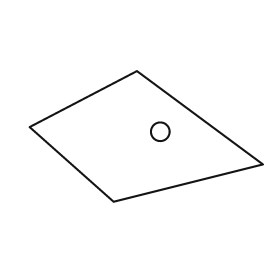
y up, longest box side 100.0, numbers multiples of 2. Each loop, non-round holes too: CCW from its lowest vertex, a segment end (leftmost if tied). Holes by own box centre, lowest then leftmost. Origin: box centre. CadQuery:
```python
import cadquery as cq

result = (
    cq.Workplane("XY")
    .moveTo(-14.0, -28.0)
    .lineTo(50.0, -12.0)
    .lineTo(-4.0, 28.0)
    .lineTo(-50.0, 4.0)
    .close()
    .moveTo(6.0, 2.0)
    .circle(4.0)
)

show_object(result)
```